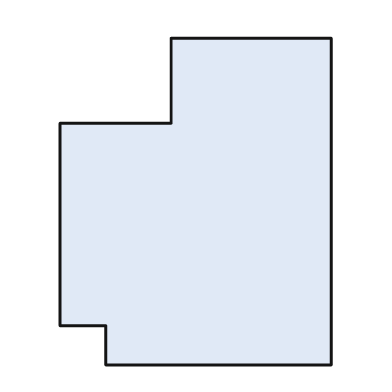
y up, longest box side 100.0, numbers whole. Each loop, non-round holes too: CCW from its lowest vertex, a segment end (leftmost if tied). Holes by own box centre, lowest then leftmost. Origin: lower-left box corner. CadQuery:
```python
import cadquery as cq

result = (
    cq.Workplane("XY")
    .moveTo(14.0, 0.0)
    .lineTo(83.0, 0.0)
    .lineTo(83.0, 100.0)
    .lineTo(34.0, 100.0)
    .lineTo(34.0, 74.0)
    .lineTo(0.0, 74.0)
    .lineTo(0.0, 12.0)
    .lineTo(14.0, 12.0)
    .close()
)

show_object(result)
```